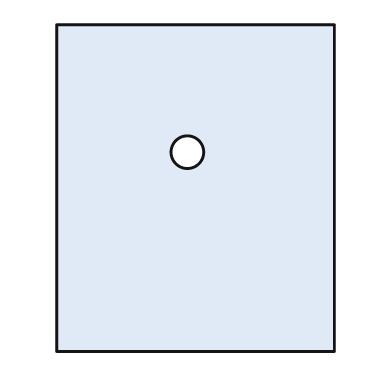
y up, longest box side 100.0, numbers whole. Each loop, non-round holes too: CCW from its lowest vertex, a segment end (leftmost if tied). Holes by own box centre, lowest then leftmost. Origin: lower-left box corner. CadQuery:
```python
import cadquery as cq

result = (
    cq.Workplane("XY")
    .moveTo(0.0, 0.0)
    .lineTo(85.0, 0.0)
    .lineTo(85.0, 100.0)
    .lineTo(0.0, 100.0)
    .close()
    .moveTo(40.0, 61.0)
    .circle(5.0)
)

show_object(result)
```